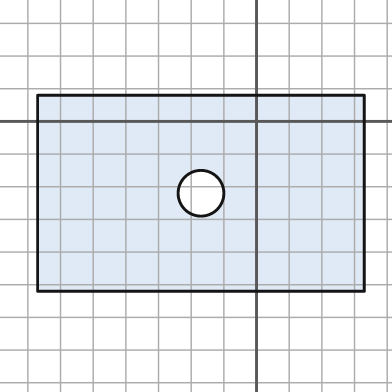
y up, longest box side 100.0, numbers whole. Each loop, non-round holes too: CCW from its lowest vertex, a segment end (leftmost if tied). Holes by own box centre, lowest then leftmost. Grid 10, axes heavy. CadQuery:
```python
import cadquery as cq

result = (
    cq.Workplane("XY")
    .moveTo(-67.0, -52.0)
    .lineTo(33.0, -52.0)
    .lineTo(33.0, 8.0)
    .lineTo(-67.0, 8.0)
    .close()
    .moveTo(-17.0, -22.0)
    .circle(7.0)
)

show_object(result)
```